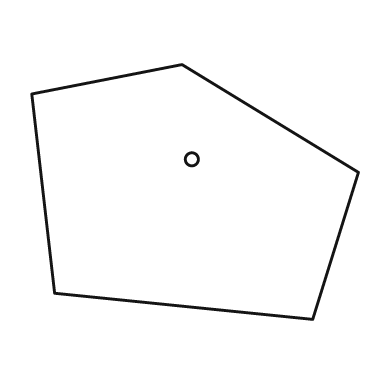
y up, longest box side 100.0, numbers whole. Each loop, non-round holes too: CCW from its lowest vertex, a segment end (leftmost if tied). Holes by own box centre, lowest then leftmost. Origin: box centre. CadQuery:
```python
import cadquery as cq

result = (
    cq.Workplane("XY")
    .moveTo(36.0, -39.0)
    .lineTo(50.0, 6.0)
    .lineTo(-4.0, 39.0)
    .lineTo(-50.0, 30.0)
    .lineTo(-43.0, -31.0)
    .close()
    .moveTo(-1.0, 10.0)
    .circle(2.0)
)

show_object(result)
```